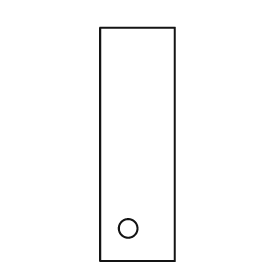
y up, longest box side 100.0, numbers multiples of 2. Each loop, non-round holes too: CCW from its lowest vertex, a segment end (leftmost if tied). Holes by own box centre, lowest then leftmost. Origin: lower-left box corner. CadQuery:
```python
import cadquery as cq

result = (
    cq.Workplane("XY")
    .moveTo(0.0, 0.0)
    .lineTo(32.0, 0.0)
    .lineTo(32.0, 100.0)
    .lineTo(0.0, 100.0)
    .close()
    .moveTo(12.0, 14.0)
    .circle(4.0)
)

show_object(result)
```